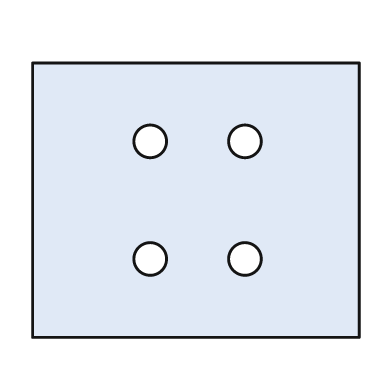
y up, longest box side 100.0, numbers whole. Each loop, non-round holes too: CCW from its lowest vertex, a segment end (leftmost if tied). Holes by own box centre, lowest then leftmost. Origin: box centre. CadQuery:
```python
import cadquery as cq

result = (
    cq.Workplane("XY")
    .moveTo(-50.0, -42.0)
    .lineTo(50.0, -42.0)
    .lineTo(50.0, 42.0)
    .lineTo(-50.0, 42.0)
    .close()
    .moveTo(-14.0, -18.0)
    .circle(5.0)
    .moveTo(15.0, -18.0)
    .circle(5.0)
    .moveTo(-14.0, 18.0)
    .circle(5.0)
    .moveTo(15.0, 18.0)
    .circle(5.0)
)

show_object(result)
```